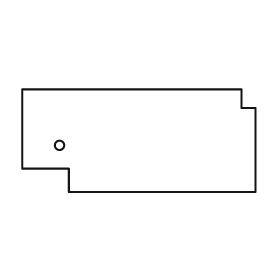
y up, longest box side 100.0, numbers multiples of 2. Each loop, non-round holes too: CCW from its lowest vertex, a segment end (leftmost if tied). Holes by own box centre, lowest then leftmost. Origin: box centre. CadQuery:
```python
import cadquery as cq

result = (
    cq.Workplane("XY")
    .moveTo(-30.0, -22.0)
    .lineTo(50.0, -22.0)
    .lineTo(50.0, 14.0)
    .lineTo(44.0, 14.0)
    .lineTo(44.0, 22.0)
    .lineTo(-50.0, 22.0)
    .lineTo(-50.0, -12.0)
    .lineTo(-30.0, -12.0)
    .close()
    .moveTo(-34.0, -2.0)
    .circle(2.0)
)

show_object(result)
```